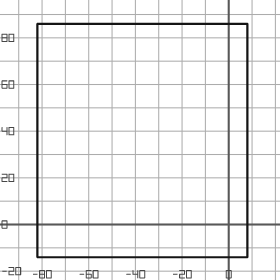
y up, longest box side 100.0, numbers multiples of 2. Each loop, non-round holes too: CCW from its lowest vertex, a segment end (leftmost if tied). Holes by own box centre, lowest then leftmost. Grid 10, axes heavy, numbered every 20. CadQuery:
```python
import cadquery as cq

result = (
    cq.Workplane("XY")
    .moveTo(-82.0, -14.0)
    .lineTo(8.0, -14.0)
    .lineTo(8.0, 86.0)
    .lineTo(-82.0, 86.0)
    .close()
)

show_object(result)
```